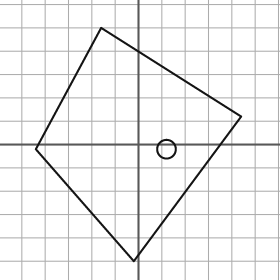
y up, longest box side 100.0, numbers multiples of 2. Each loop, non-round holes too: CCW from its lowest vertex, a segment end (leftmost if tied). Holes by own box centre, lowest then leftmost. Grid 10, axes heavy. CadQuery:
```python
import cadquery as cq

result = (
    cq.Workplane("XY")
    .moveTo(-2.0, -50.0)
    .lineTo(44.0, 12.0)
    .lineTo(-16.0, 50.0)
    .lineTo(-44.0, -2.0)
    .close()
    .moveTo(12.0, -2.0)
    .circle(4.0)
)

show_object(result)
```